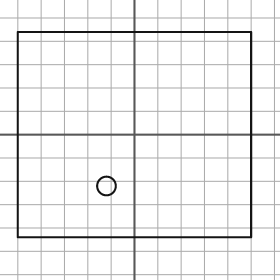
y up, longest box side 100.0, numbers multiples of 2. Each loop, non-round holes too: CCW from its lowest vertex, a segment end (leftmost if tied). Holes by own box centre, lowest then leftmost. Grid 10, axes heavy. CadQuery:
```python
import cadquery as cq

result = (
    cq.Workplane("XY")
    .moveTo(-50.0, -44.0)
    .lineTo(50.0, -44.0)
    .lineTo(50.0, 44.0)
    .lineTo(-50.0, 44.0)
    .close()
    .moveTo(-12.0, -22.0)
    .circle(4.0)
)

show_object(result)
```